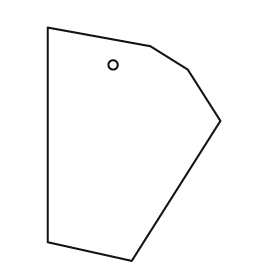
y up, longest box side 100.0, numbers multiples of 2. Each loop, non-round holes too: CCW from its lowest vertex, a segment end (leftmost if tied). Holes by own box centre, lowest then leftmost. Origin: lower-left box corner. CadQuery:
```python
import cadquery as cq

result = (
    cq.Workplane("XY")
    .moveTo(36.0, 0.0)
    .lineTo(74.0, 60.0)
    .lineTo(60.0, 82.0)
    .lineTo(44.0, 92.0)
    .lineTo(0.0, 100.0)
    .lineTo(0.0, 8.0)
    .close()
    .moveTo(28.0, 84.0)
    .circle(2.0)
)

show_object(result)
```